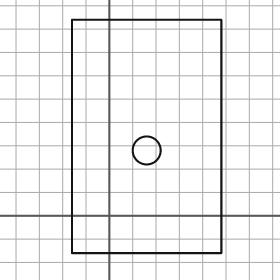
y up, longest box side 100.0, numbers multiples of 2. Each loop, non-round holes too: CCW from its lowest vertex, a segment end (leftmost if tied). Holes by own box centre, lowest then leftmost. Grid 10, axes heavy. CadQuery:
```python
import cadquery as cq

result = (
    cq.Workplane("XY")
    .moveTo(-16.0, -16.0)
    .lineTo(48.0, -16.0)
    .lineTo(48.0, 84.0)
    .lineTo(-16.0, 84.0)
    .close()
    .moveTo(16.0, 28.0)
    .circle(6.0)
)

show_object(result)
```